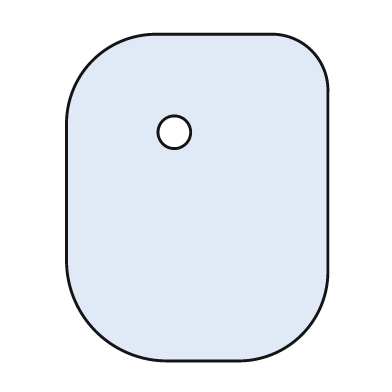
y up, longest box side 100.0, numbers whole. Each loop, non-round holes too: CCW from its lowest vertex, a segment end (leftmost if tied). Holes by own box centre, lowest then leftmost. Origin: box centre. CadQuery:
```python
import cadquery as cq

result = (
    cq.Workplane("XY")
    .moveTo(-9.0, -50.0)
    .lineTo(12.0, -50.0)
    .threePointArc((32.0, -42.0), (40.0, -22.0))
    .lineTo(40.0, 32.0)
    .threePointArc((35.0, 45.0), (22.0, 50.0))
    .lineTo(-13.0, 50.0)
    .threePointArc((-32.0, 42.0), (-40.0, 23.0))
    .lineTo(-40.0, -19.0)
    .threePointArc((-31.0, -41.0), (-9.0, -50.0))
    .close()
    .moveTo(-7.0, 20.0)
    .circle(5.0)
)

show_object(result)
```